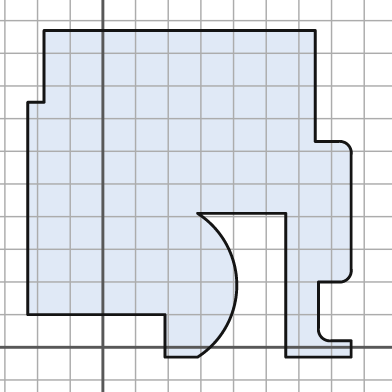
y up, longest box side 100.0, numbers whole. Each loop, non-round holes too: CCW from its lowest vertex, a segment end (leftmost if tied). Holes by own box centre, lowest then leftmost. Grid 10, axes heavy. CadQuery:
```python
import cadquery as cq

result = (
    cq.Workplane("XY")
    .moveTo(19.0, -3.0)
    .lineTo(29.0, -3.0)
    .threePointArc((41.0, 19.0), (29.0, 41.0))
    .lineTo(56.0, 41.0)
    .lineTo(56.0, -3.0)
    .lineTo(76.0, -3.0)
    .lineTo(76.0, 2.0)
    .lineTo(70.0, 2.0)
    .threePointArc((67.0, 3.0), (66.0, 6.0))
    .lineTo(66.0, 20.0)
    .lineTo(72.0, 20.0)
    .threePointArc((75.0, 21.0), (76.0, 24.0))
    .lineTo(76.0, 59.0)
    .threePointArc((75.0, 62.0), (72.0, 63.0))
    .lineTo(65.0, 63.0)
    .lineTo(65.0, 97.0)
    .lineTo(-18.0, 97.0)
    .lineTo(-18.0, 75.0)
    .lineTo(-23.0, 75.0)
    .lineTo(-23.0, 10.0)
    .lineTo(19.0, 10.0)
    .close()
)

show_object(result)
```